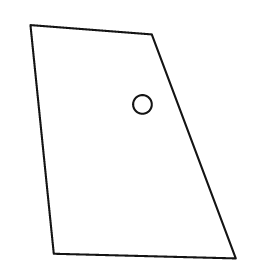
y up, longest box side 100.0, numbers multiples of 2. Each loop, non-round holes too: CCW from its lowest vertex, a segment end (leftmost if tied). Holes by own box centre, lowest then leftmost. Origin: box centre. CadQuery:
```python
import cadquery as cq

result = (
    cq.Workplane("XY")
    .moveTo(44.0, -50.0)
    .lineTo(8.0, 46.0)
    .lineTo(-44.0, 50.0)
    .lineTo(-34.0, -48.0)
    .close()
    .moveTo(4.0, 16.0)
    .circle(4.0)
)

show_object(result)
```